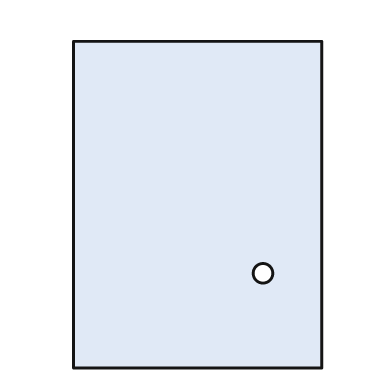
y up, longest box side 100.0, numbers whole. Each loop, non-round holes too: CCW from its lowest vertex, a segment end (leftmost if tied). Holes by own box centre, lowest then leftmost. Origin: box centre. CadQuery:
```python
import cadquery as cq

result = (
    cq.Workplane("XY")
    .moveTo(-38.0, -50.0)
    .lineTo(38.0, -50.0)
    .lineTo(38.0, 50.0)
    .lineTo(-38.0, 50.0)
    .close()
    .moveTo(20.0, -21.0)
    .circle(3.0)
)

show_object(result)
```